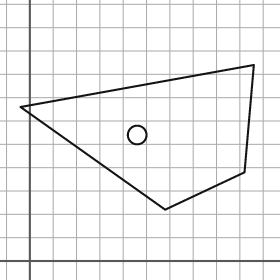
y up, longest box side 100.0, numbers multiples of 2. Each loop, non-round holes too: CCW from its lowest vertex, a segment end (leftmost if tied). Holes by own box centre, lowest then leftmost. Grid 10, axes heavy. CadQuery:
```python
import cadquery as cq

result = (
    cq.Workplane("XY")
    .moveTo(58.0, 22.0)
    .lineTo(92.0, 38.0)
    .lineTo(96.0, 84.0)
    .lineTo(-4.0, 66.0)
    .close()
    .moveTo(46.0, 54.0)
    .circle(4.0)
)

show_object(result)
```